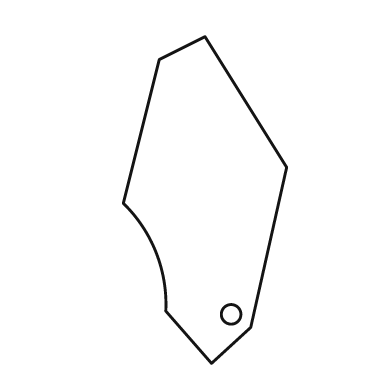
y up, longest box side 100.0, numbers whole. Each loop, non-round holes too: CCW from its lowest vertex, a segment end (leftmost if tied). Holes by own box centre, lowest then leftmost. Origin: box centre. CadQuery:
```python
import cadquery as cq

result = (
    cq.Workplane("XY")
    .moveTo(2.0, -50.0)
    .lineTo(14.0, -39.0)
    .lineTo(25.0, 10.0)
    .lineTo(0.0, 50.0)
    .lineTo(-14.0, 43.0)
    .lineTo(-25.0, -1.0)
    .threePointArc((-15.0, -16.0), (-12.0, -34.0))
    .close()
    .moveTo(8.0, -35.0)
    .circle(3.0)
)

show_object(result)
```